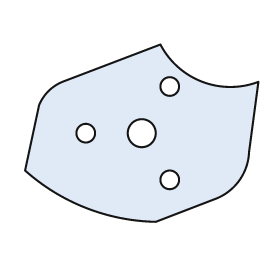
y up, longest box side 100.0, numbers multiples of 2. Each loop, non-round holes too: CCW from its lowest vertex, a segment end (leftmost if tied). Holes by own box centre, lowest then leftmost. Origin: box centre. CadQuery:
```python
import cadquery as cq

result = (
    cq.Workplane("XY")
    .moveTo(6.0, -38.0)
    .lineTo(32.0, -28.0)
    .threePointArc((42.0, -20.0), (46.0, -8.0))
    .lineTo(50.0, 22.0)
    .threePointArc((26.0, 22.0), (8.0, 38.0))
    .lineTo(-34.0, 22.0)
    .threePointArc((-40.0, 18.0), (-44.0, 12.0))
    .lineTo(-50.0, -16.0)
    .threePointArc((-24.0, -32.0), (6.0, -38.0))
    .close()
    .moveTo(12.0, -20.0)
    .circle(4.0)
    .moveTo(-24.0, 0.0)
    .circle(4.0)
    .moveTo(0.0, 0.0)
    .circle(6.0)
    .moveTo(12.0, 20.0)
    .circle(4.0)
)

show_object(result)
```